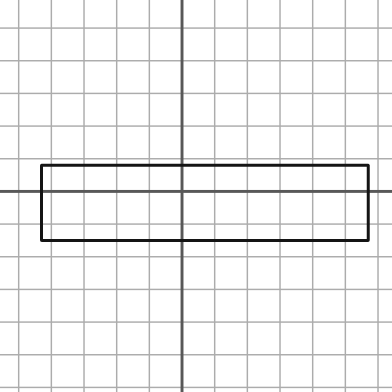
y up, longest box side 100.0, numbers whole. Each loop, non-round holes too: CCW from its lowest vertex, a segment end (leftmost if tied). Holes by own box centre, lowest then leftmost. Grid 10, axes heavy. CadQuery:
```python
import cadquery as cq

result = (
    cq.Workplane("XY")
    .moveTo(-43.0, -15.0)
    .lineTo(57.0, -15.0)
    .lineTo(57.0, 8.0)
    .lineTo(-43.0, 8.0)
    .close()
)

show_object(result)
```